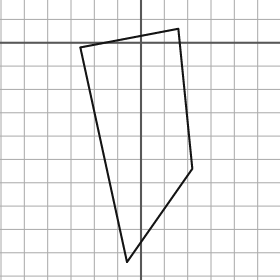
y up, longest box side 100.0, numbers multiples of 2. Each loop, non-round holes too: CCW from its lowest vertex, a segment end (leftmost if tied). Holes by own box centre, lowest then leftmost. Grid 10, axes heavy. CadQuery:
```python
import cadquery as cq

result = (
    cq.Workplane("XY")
    .moveTo(-6.0, -94.0)
    .lineTo(22.0, -54.0)
    .lineTo(16.0, 6.0)
    .lineTo(-26.0, -2.0)
    .close()
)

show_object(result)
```